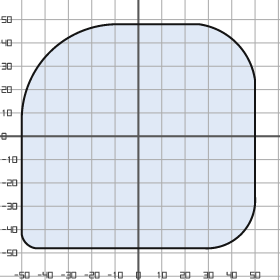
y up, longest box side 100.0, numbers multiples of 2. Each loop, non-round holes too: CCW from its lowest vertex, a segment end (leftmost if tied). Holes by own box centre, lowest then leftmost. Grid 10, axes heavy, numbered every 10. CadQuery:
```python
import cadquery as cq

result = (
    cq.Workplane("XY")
    .moveTo(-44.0, -48.0)
    .lineTo(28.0, -48.0)
    .threePointArc((44.0, -42.0), (50.0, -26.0))
    .lineTo(50.0, 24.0)
    .threePointArc((42.0, 40.0), (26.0, 48.0))
    .lineTo(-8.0, 48.0)
    .threePointArc((-38.0, 36.0), (-50.0, 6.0))
    .lineTo(-50.0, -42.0)
    .threePointArc((-48.0, -46.0), (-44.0, -48.0))
    .close()
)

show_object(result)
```